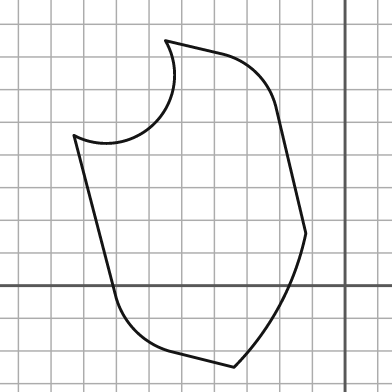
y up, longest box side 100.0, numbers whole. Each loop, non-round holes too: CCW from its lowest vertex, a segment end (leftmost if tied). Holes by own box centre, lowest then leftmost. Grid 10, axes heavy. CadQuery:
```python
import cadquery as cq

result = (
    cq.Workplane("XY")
    .moveTo(-34.0, -25.0)
    .threePointArc((-20.0, -6.0), (-12.0, 16.0))
    .lineTo(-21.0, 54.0)
    .threePointArc((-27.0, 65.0), (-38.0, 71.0))
    .lineTo(-55.0, 75.0)
    .threePointArc((-58.0, 50.0), (-83.0, 46.0))
    .lineTo(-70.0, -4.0)
    .threePointArc((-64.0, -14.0), (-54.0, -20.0))
    .close()
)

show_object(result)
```